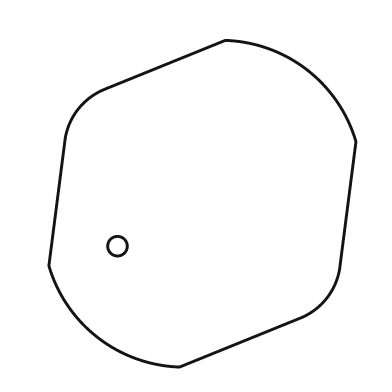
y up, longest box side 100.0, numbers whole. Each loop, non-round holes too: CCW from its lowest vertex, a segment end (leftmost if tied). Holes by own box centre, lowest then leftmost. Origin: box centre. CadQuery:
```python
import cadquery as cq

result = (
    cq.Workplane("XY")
    .moveTo(-7.0, -50.0)
    .lineTo(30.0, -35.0)
    .threePointArc((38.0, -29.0), (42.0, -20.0))
    .lineTo(47.0, 19.0)
    .threePointArc((32.0, 41.0), (7.0, 50.0))
    .lineTo(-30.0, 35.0)
    .threePointArc((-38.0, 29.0), (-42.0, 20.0))
    .lineTo(-47.0, -19.0)
    .threePointArc((-32.0, -41.0), (-7.0, -50.0))
    .close()
    .moveTo(-26.0, -13.0)
    .circle(3.0)
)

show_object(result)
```